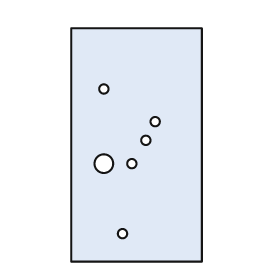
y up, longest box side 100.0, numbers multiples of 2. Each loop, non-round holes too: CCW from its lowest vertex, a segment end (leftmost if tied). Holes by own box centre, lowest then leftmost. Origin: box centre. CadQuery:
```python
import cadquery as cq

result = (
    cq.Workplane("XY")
    .moveTo(-28.0, -50.0)
    .lineTo(28.0, -50.0)
    .lineTo(28.0, 50.0)
    .lineTo(-28.0, 50.0)
    .close()
    .moveTo(-6.0, -38.0)
    .circle(2.0)
    .moveTo(-14.0, -8.0)
    .circle(4.0)
    .moveTo(-2.0, -8.0)
    .circle(2.0)
    .moveTo(4.0, 2.0)
    .circle(2.0)
    .moveTo(8.0, 10.0)
    .circle(2.0)
    .moveTo(-14.0, 24.0)
    .circle(2.0)
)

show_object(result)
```